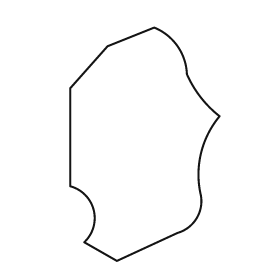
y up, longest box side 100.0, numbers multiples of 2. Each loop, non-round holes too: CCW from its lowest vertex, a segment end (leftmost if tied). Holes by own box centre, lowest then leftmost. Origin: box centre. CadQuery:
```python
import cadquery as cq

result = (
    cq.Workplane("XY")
    .moveTo(-12.0, -50.0)
    .lineTo(14.0, -38.0)
    .threePointArc((22.0, -32.0), (24.0, -22.0))
    .threePointArc((24.0, -4.0), (32.0, 12.0))
    .threePointArc((24.0, 20.0), (18.0, 30.0))
    .threePointArc((14.0, 42.0), (4.0, 50.0))
    .lineTo(-16.0, 42.0)
    .lineTo(-32.0, 24.0)
    .lineTo(-32.0, -18.0)
    .threePointArc((-22.0, -28.0), (-26.0, -42.0))
    .close()
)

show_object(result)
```